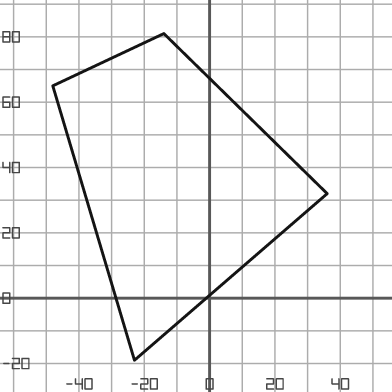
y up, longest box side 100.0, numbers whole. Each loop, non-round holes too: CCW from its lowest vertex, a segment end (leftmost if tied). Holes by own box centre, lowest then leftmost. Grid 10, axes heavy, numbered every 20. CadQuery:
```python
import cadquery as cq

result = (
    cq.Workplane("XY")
    .moveTo(-23.0, -19.0)
    .lineTo(36.0, 32.0)
    .lineTo(-14.0, 81.0)
    .lineTo(-48.0, 65.0)
    .close()
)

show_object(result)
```